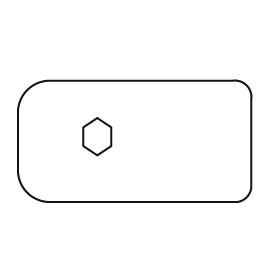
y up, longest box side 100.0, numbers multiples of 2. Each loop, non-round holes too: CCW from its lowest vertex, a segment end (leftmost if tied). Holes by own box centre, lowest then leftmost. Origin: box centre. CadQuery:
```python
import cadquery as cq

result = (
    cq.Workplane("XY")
    .moveTo(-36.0, -26.0)
    .lineTo(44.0, -26.0)
    .threePointArc((48.0, -24.0), (50.0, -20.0))
    .lineTo(50.0, 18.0)
    .threePointArc((48.0, 24.0), (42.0, 26.0))
    .lineTo(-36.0, 26.0)
    .threePointArc((-46.0, 22.0), (-50.0, 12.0))
    .lineTo(-50.0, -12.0)
    .threePointArc((-46.0, -22.0), (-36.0, -26.0))
    .close()
    .moveTo(-16.0, -6.0)
    .lineTo(-10.0, -2.0)
    .lineTo(-10.0, 6.0)
    .lineTo(-16.0, 10.0)
    .lineTo(-22.0, 6.0)
    .lineTo(-22.0, -2.0)
    .close()
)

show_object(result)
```